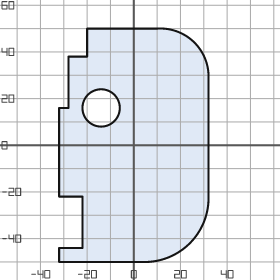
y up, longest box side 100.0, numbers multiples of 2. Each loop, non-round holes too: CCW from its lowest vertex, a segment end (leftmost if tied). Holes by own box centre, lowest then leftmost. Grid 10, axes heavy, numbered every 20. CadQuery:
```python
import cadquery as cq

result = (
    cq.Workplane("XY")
    .moveTo(-32.0, -50.0)
    .lineTo(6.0, -50.0)
    .threePointArc((24.0, -42.0), (32.0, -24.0))
    .lineTo(32.0, 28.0)
    .threePointArc((26.0, 44.0), (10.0, 50.0))
    .lineTo(-20.0, 50.0)
    .lineTo(-20.0, 38.0)
    .lineTo(-28.0, 38.0)
    .lineTo(-28.0, 16.0)
    .lineTo(-32.0, 16.0)
    .lineTo(-32.0, -22.0)
    .lineTo(-22.0, -22.0)
    .lineTo(-22.0, -44.0)
    .lineTo(-32.0, -44.0)
    .close()
    .moveTo(-14.0, 16.0)
    .circle(8.0)
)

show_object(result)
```